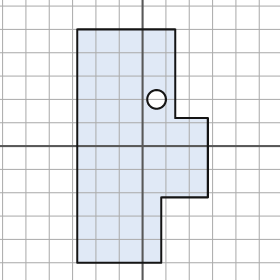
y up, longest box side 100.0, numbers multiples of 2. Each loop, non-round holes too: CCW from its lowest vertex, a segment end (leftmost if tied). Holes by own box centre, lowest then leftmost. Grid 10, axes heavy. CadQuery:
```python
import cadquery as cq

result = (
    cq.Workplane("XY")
    .moveTo(-28.0, -50.0)
    .lineTo(8.0, -50.0)
    .lineTo(8.0, -22.0)
    .lineTo(28.0, -22.0)
    .lineTo(28.0, 12.0)
    .lineTo(14.0, 12.0)
    .lineTo(14.0, 50.0)
    .lineTo(-28.0, 50.0)
    .close()
    .moveTo(6.0, 20.0)
    .circle(4.0)
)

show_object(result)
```